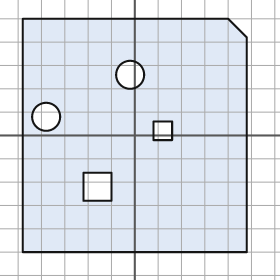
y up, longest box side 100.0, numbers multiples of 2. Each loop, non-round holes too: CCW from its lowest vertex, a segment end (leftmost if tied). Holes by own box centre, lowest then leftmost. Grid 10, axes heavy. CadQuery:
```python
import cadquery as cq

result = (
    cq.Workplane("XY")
    .moveTo(-48.0, -50.0)
    .lineTo(48.0, -50.0)
    .lineTo(48.0, 42.0)
    .lineTo(40.0, 50.0)
    .lineTo(-48.0, 50.0)
    .close()
    .moveTo(-22.0, -28.0)
    .lineTo(-10.0, -28.0)
    .lineTo(-10.0, -16.0)
    .lineTo(-22.0, -16.0)
    .close()
    .moveTo(8.0, -2.0)
    .lineTo(16.0, -2.0)
    .lineTo(16.0, 6.0)
    .lineTo(8.0, 6.0)
    .close()
    .moveTo(-38.0, 8.0)
    .circle(6.0)
    .moveTo(-2.0, 26.0)
    .circle(6.0)
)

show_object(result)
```